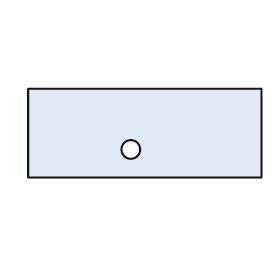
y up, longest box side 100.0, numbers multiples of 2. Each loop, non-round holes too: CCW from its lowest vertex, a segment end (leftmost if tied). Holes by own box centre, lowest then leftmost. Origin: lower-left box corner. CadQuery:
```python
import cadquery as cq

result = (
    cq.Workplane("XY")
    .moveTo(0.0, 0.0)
    .lineTo(100.0, 0.0)
    .lineTo(100.0, 38.0)
    .lineTo(0.0, 38.0)
    .close()
    .moveTo(44.0, 12.0)
    .circle(4.0)
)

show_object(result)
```